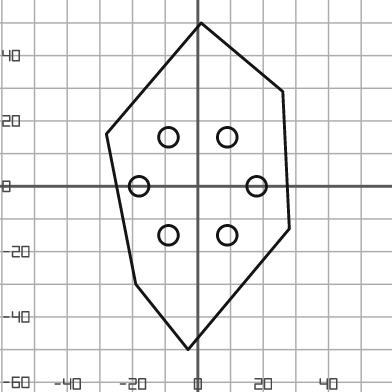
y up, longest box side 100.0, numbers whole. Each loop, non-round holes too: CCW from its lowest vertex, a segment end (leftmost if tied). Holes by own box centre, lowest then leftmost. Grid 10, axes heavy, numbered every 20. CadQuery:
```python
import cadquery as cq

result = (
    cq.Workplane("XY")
    .moveTo(-3.0, -50.0)
    .lineTo(28.0, -13.0)
    .lineTo(26.0, 29.0)
    .lineTo(1.0, 50.0)
    .lineTo(-28.0, 16.0)
    .lineTo(-19.0, -30.0)
    .close()
    .moveTo(-9.0, -15.0)
    .circle(3.0)
    .moveTo(9.0, -15.0)
    .circle(3.0)
    .moveTo(-18.0, 0.0)
    .circle(3.0)
    .moveTo(18.0, 0.0)
    .circle(3.0)
    .moveTo(-9.0, 15.0)
    .circle(3.0)
    .moveTo(9.0, 15.0)
    .circle(3.0)
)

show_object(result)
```